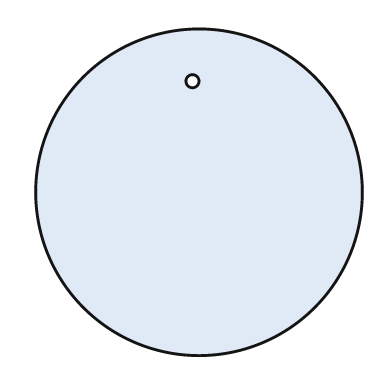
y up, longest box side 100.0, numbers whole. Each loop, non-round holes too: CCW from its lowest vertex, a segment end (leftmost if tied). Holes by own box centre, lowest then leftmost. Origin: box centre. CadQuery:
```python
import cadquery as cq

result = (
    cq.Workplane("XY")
    .moveTo(0.0, 0.0)
    .circle(50.0)
    .moveTo(-2.0, 34.0)
    .circle(2.0)
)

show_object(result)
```